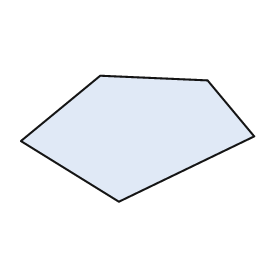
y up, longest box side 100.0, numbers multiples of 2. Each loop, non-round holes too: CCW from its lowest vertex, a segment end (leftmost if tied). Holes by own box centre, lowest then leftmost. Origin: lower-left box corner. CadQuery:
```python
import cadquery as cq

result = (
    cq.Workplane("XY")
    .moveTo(42.0, 0.0)
    .lineTo(100.0, 28.0)
    .lineTo(80.0, 52.0)
    .lineTo(34.0, 54.0)
    .lineTo(0.0, 26.0)
    .close()
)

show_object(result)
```